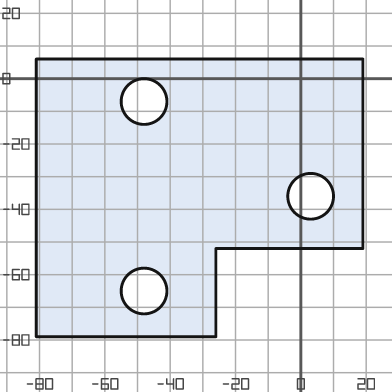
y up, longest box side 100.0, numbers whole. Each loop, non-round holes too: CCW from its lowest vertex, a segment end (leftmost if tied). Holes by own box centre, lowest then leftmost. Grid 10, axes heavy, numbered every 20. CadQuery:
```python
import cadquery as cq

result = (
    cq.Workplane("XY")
    .moveTo(-81.0, -79.0)
    .lineTo(-26.0, -79.0)
    .lineTo(-26.0, -52.0)
    .lineTo(19.0, -52.0)
    .lineTo(19.0, 6.0)
    .lineTo(-81.0, 6.0)
    .close()
    .moveTo(-48.0, -65.0)
    .circle(7.0)
    .moveTo(3.0, -36.0)
    .circle(7.0)
    .moveTo(-48.0, -7.0)
    .circle(7.0)
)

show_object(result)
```